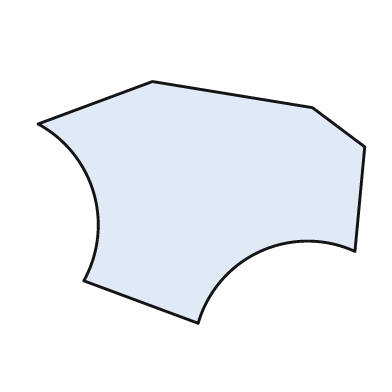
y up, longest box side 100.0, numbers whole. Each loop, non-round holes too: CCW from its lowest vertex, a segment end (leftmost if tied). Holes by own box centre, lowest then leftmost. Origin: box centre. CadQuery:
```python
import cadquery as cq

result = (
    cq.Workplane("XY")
    .moveTo(-1.0, -37.0)
    .threePointArc((18.0, -15.0), (47.0, -15.0))
    .lineTo(50.0, 17.0)
    .lineTo(34.0, 29.0)
    .lineTo(-15.0, 37.0)
    .lineTo(-50.0, 24.0)
    .threePointArc((-33.0, 3.0), (-36.0, -24.0))
    .close()
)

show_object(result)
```